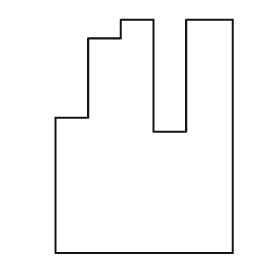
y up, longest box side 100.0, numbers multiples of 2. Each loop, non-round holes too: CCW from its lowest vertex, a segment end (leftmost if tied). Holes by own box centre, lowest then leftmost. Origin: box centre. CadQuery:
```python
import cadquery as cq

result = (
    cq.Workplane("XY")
    .moveTo(-38.0, -50.0)
    .lineTo(38.0, -50.0)
    .lineTo(38.0, 50.0)
    .lineTo(18.0, 50.0)
    .lineTo(18.0, 2.0)
    .lineTo(4.0, 2.0)
    .lineTo(4.0, 50.0)
    .lineTo(-10.0, 50.0)
    .lineTo(-10.0, 42.0)
    .lineTo(-24.0, 42.0)
    .lineTo(-24.0, 8.0)
    .lineTo(-38.0, 8.0)
    .close()
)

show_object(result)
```